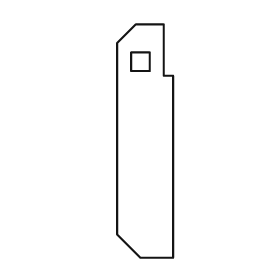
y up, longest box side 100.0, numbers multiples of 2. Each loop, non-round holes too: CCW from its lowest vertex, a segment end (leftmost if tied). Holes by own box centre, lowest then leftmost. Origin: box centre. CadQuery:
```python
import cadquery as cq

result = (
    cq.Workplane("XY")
    .moveTo(-2.0, -50.0)
    .lineTo(12.0, -50.0)
    .lineTo(12.0, 28.0)
    .lineTo(8.0, 28.0)
    .lineTo(8.0, 50.0)
    .lineTo(-4.0, 50.0)
    .lineTo(-12.0, 42.0)
    .lineTo(-12.0, -40.0)
    .close()
    .moveTo(-6.0, 30.0)
    .lineTo(2.0, 30.0)
    .lineTo(2.0, 38.0)
    .lineTo(-6.0, 38.0)
    .close()
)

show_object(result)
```